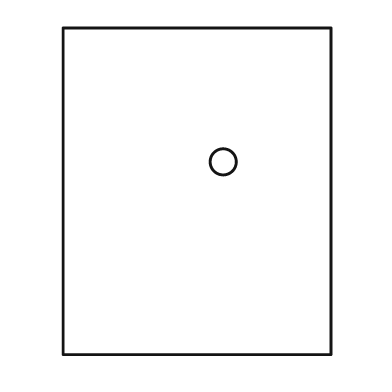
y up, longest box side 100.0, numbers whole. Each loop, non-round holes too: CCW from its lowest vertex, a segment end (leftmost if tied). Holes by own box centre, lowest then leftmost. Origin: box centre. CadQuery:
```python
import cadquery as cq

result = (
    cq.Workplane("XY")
    .moveTo(-41.0, -50.0)
    .lineTo(41.0, -50.0)
    .lineTo(41.0, 50.0)
    .lineTo(-41.0, 50.0)
    .close()
    .moveTo(8.0, 9.0)
    .circle(4.0)
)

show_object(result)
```